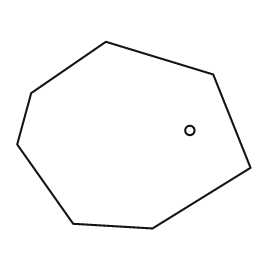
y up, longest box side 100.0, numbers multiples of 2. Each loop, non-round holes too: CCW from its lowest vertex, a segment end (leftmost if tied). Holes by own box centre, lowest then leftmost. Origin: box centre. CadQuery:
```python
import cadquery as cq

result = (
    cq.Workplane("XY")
    .moveTo(8.0, -40.0)
    .lineTo(50.0, -14.0)
    .lineTo(34.0, 26.0)
    .lineTo(-12.0, 40.0)
    .lineTo(-44.0, 18.0)
    .lineTo(-50.0, -4.0)
    .lineTo(-26.0, -38.0)
    .close()
    .moveTo(24.0, 2.0)
    .circle(2.0)
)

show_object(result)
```